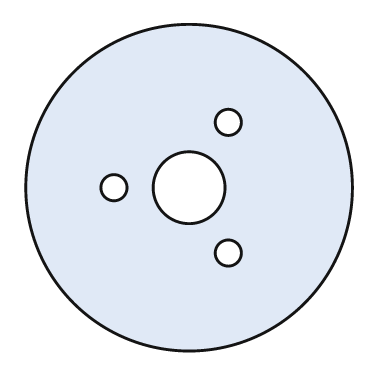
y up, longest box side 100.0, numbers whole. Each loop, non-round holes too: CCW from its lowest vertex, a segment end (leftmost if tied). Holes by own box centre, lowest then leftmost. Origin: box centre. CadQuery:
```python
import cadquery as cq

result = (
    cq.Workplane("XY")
    .moveTo(0.0, 0.0)
    .circle(50.0)
    .moveTo(12.0, -20.0)
    .circle(4.0)
    .moveTo(-23.0, 0.0)
    .circle(4.0)
    .moveTo(0.0, 0.0)
    .circle(11.0)
    .moveTo(12.0, 20.0)
    .circle(4.0)
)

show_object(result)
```